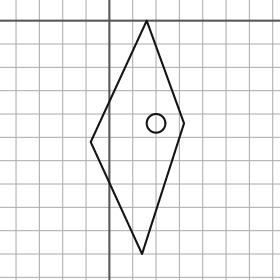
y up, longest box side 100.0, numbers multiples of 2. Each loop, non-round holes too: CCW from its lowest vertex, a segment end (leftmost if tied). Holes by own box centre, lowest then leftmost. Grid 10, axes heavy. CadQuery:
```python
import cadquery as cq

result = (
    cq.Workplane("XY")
    .moveTo(14.0, -100.0)
    .lineTo(32.0, -44.0)
    .lineTo(16.0, 0.0)
    .lineTo(-8.0, -52.0)
    .close()
    .moveTo(20.0, -44.0)
    .circle(4.0)
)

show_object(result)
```